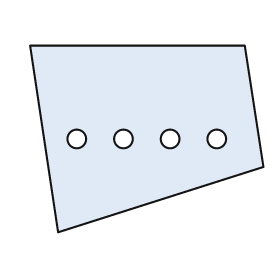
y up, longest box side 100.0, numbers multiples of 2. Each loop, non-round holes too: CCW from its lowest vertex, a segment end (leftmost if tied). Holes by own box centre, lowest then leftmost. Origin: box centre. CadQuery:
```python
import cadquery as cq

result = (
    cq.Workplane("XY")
    .moveTo(-38.0, -40.0)
    .lineTo(50.0, -12.0)
    .lineTo(42.0, 40.0)
    .lineTo(-50.0, 40.0)
    .close()
    .moveTo(-30.0, 0.0)
    .circle(4.0)
    .moveTo(-10.0, 0.0)
    .circle(4.0)
    .moveTo(10.0, 0.0)
    .circle(4.0)
    .moveTo(30.0, 0.0)
    .circle(4.0)
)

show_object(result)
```